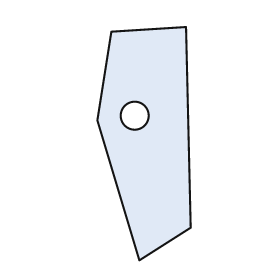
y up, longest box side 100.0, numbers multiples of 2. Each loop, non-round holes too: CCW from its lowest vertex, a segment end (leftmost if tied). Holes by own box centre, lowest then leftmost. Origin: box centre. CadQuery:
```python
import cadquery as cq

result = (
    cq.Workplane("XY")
    .moveTo(-2.0, -50.0)
    .lineTo(20.0, -36.0)
    .lineTo(18.0, 50.0)
    .lineTo(-14.0, 48.0)
    .lineTo(-20.0, 10.0)
    .close()
    .moveTo(-4.0, 12.0)
    .circle(6.0)
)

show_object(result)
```